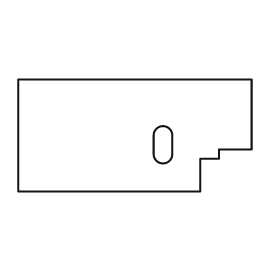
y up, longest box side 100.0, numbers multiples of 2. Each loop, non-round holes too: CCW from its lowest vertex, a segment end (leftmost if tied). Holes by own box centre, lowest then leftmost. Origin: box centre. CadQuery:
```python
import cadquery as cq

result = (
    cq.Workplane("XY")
    .moveTo(-50.0, -24.0)
    .lineTo(28.0, -24.0)
    .lineTo(28.0, -10.0)
    .lineTo(36.0, -10.0)
    .lineTo(36.0, -6.0)
    .lineTo(50.0, -6.0)
    .lineTo(50.0, 24.0)
    .lineTo(-50.0, 24.0)
    .close()
    .moveTo(8.0, -8.0)
    .threePointArc((12.0, -12.0), (16.0, -8.0))
    .lineTo(16.0, 0.0)
    .threePointArc((12.0, 4.0), (8.0, 0.0))
    .close()
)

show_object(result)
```